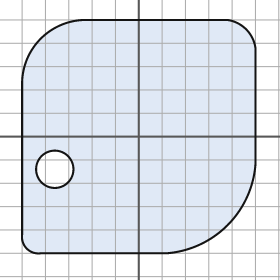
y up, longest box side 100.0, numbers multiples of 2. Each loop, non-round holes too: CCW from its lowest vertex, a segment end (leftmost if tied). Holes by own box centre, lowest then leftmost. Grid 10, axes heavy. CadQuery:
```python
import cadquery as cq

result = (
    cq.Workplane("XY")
    .moveTo(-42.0, -50.0)
    .lineTo(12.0, -50.0)
    .threePointArc((38.0, -38.0), (50.0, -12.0))
    .lineTo(50.0, 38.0)
    .threePointArc((46.0, 46.0), (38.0, 50.0))
    .lineTo(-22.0, 50.0)
    .threePointArc((-42.0, 42.0), (-50.0, 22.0))
    .lineTo(-50.0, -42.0)
    .threePointArc((-48.0, -48.0), (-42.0, -50.0))
    .close()
    .moveTo(-36.0, -14.0)
    .circle(8.0)
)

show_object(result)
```